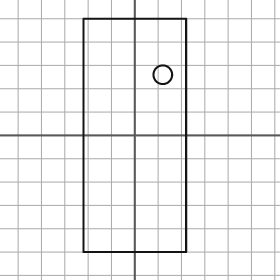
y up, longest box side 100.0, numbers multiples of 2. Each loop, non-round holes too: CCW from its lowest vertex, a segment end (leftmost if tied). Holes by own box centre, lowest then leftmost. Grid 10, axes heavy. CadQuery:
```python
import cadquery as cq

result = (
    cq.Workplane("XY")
    .moveTo(-22.0, -50.0)
    .lineTo(22.0, -50.0)
    .lineTo(22.0, 50.0)
    .lineTo(-22.0, 50.0)
    .close()
    .moveTo(12.0, 26.0)
    .circle(4.0)
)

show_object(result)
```